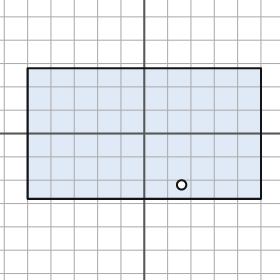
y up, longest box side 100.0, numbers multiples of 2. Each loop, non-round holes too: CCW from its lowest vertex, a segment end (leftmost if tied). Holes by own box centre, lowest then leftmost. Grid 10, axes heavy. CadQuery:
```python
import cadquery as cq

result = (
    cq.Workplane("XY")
    .moveTo(-50.0, -28.0)
    .lineTo(50.0, -28.0)
    .lineTo(50.0, 28.0)
    .lineTo(-50.0, 28.0)
    .close()
    .moveTo(16.0, -22.0)
    .circle(2.0)
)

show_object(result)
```